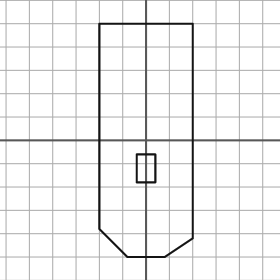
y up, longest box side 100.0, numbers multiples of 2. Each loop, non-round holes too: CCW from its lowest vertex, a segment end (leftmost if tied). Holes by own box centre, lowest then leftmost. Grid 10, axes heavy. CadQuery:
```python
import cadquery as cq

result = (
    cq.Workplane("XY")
    .moveTo(-8.0, -50.0)
    .lineTo(8.0, -50.0)
    .lineTo(20.0, -42.0)
    .lineTo(20.0, 50.0)
    .lineTo(-20.0, 50.0)
    .lineTo(-20.0, -38.0)
    .close()
    .moveTo(-4.0, -18.0)
    .lineTo(4.0, -18.0)
    .lineTo(4.0, -6.0)
    .lineTo(-4.0, -6.0)
    .close()
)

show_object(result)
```